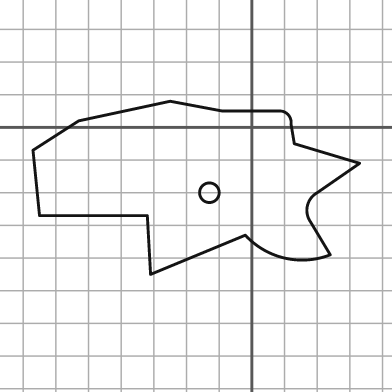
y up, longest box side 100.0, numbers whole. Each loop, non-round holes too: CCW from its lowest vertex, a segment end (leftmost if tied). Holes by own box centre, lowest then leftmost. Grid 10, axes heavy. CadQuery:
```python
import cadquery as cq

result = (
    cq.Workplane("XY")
    .moveTo(-31.0, -45.0)
    .lineTo(-2.0, -33.0)
    .threePointArc((10.0, -40.0), (24.0, -39.0))
    .lineTo(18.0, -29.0)
    .threePointArc((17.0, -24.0), (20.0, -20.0))
    .lineTo(33.0, -11.0)
    .lineTo(13.0, -5.0)
    .lineTo(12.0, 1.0)
    .threePointArc((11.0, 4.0), (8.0, 5.0))
    .lineTo(-9.0, 5.0)
    .lineTo(-25.0, 8.0)
    .lineTo(-53.0, 2.0)
    .lineTo(-67.0, -7.0)
    .lineTo(-65.0, -27.0)
    .lineTo(-32.0, -27.0)
    .close()
    .moveTo(-13.0, -20.0)
    .circle(3.0)
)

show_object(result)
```